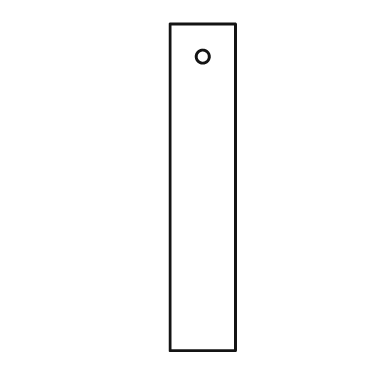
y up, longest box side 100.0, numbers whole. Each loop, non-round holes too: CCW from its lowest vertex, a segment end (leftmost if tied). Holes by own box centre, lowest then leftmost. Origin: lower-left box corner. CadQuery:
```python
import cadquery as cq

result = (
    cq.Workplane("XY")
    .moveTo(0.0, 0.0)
    .lineTo(20.0, 0.0)
    .lineTo(20.0, 100.0)
    .lineTo(0.0, 100.0)
    .close()
    .moveTo(10.0, 90.0)
    .circle(2.0)
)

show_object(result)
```